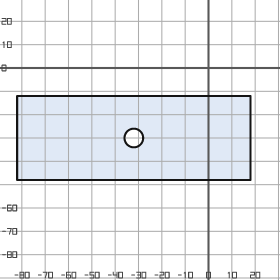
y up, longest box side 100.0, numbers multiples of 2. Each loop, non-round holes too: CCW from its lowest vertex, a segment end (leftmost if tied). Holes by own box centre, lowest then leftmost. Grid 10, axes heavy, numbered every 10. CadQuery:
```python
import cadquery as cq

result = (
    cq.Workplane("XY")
    .moveTo(-82.0, -48.0)
    .lineTo(18.0, -48.0)
    .lineTo(18.0, -12.0)
    .lineTo(-82.0, -12.0)
    .close()
    .moveTo(-32.0, -30.0)
    .circle(4.0)
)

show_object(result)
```